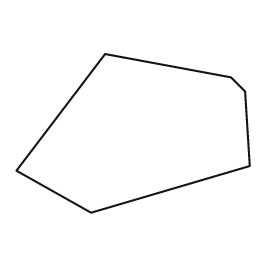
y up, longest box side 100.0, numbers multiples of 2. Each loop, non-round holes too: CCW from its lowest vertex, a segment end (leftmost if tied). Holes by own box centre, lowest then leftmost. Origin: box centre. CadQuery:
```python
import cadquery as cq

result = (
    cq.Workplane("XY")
    .moveTo(-18.0, -34.0)
    .lineTo(50.0, -14.0)
    .lineTo(48.0, 18.0)
    .lineTo(42.0, 24.0)
    .lineTo(-12.0, 34.0)
    .lineTo(-50.0, -16.0)
    .close()
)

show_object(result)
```